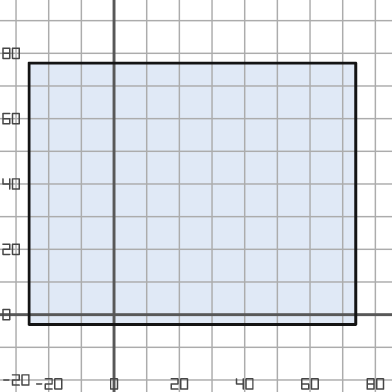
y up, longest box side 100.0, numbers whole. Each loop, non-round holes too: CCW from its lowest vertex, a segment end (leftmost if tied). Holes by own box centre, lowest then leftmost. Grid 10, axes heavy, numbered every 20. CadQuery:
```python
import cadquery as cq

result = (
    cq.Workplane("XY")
    .moveTo(-26.0, -3.0)
    .lineTo(74.0, -3.0)
    .lineTo(74.0, 77.0)
    .lineTo(-26.0, 77.0)
    .close()
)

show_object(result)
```